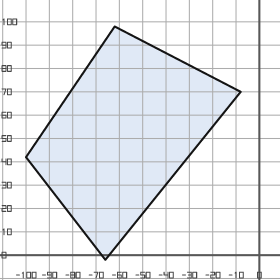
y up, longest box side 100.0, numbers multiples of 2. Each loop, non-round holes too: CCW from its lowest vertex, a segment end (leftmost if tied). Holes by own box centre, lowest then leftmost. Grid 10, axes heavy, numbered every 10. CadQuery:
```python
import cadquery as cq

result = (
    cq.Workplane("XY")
    .moveTo(-66.0, -2.0)
    .lineTo(-8.0, 70.0)
    .lineTo(-62.0, 98.0)
    .lineTo(-100.0, 42.0)
    .close()
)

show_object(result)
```